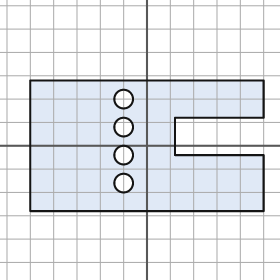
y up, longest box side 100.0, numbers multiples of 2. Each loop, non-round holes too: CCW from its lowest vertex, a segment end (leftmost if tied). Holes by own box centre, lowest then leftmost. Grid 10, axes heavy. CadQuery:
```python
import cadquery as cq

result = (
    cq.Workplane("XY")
    .moveTo(-50.0, -28.0)
    .lineTo(50.0, -28.0)
    .lineTo(50.0, -4.0)
    .lineTo(12.0, -4.0)
    .lineTo(12.0, 12.0)
    .lineTo(50.0, 12.0)
    .lineTo(50.0, 28.0)
    .lineTo(-50.0, 28.0)
    .close()
    .moveTo(-10.0, -16.0)
    .circle(4.0)
    .moveTo(-10.0, -4.0)
    .circle(4.0)
    .moveTo(-10.0, 8.0)
    .circle(4.0)
    .moveTo(-10.0, 20.0)
    .circle(4.0)
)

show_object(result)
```